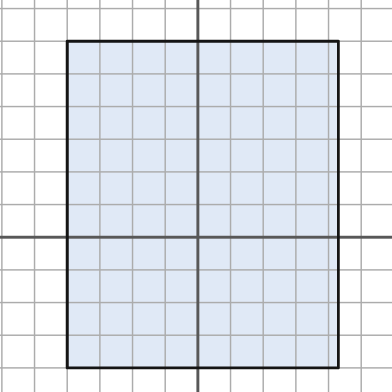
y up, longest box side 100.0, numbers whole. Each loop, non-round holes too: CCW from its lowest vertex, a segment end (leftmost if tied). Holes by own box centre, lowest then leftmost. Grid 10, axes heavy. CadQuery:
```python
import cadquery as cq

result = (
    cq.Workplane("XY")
    .moveTo(-40.0, -40.0)
    .lineTo(43.0, -40.0)
    .lineTo(43.0, 60.0)
    .lineTo(-40.0, 60.0)
    .close()
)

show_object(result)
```